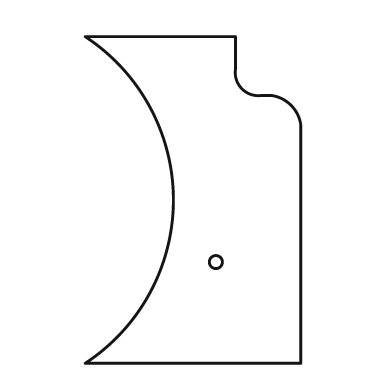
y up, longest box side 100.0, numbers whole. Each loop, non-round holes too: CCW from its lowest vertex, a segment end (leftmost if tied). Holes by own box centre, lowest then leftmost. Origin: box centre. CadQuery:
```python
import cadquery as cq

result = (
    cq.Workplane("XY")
    .moveTo(-33.0, -50.0)
    .lineTo(33.0, -50.0)
    .lineTo(33.0, 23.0)
    .threePointArc((30.0, 29.0), (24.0, 32.0))
    .lineTo(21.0, 32.0)
    .threePointArc((15.0, 34.0), (13.0, 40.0))
    .lineTo(13.0, 50.0)
    .lineTo(-33.0, 50.0)
    .threePointArc((-6.0, 0.0), (-33.0, -50.0))
    .close()
    .moveTo(7.0, -19.0)
    .circle(2.0)
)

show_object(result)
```